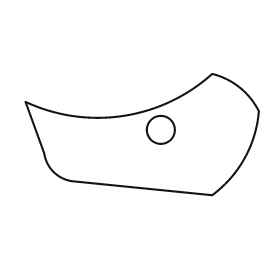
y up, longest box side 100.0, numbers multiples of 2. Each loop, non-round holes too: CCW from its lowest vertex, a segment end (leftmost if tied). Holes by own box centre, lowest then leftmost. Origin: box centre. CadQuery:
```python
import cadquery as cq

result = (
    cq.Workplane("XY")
    .moveTo(30.0, -26.0)
    .threePointArc((44.0, -10.0), (50.0, 10.0))
    .threePointArc((42.0, 20.0), (30.0, 26.0))
    .threePointArc((-8.0, 8.0), (-50.0, 14.0))
    .lineTo(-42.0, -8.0)
    .threePointArc((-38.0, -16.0), (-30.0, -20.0))
    .close()
    .moveTo(8.0, 2.0)
    .circle(6.0)
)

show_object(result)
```